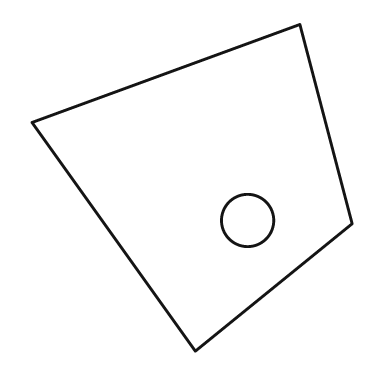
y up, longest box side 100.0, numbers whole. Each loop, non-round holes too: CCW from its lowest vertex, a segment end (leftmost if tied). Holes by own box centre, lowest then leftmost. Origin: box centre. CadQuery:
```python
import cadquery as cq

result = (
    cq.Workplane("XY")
    .moveTo(1.0, -50.0)
    .lineTo(49.0, -11.0)
    .lineTo(33.0, 50.0)
    .lineTo(-49.0, 20.0)
    .close()
    .moveTo(17.0, -10.0)
    .circle(8.0)
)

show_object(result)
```